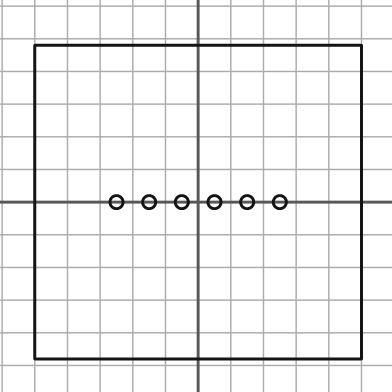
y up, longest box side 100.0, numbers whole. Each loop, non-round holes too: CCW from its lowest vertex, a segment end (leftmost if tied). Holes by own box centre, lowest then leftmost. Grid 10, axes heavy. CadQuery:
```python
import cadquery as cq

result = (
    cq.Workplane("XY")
    .moveTo(-50.0, -48.0)
    .lineTo(50.0, -48.0)
    .lineTo(50.0, 48.0)
    .lineTo(-50.0, 48.0)
    .close()
    .moveTo(-25.0, 0.0)
    .circle(2.0)
    .moveTo(-15.0, 0.0)
    .circle(2.0)
    .moveTo(-5.0, 0.0)
    .circle(2.0)
    .moveTo(5.0, 0.0)
    .circle(2.0)
    .moveTo(15.0, 0.0)
    .circle(2.0)
    .moveTo(25.0, 0.0)
    .circle(2.0)
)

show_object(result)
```